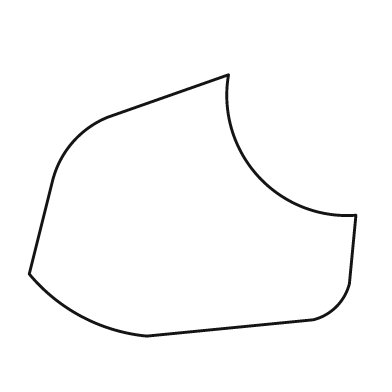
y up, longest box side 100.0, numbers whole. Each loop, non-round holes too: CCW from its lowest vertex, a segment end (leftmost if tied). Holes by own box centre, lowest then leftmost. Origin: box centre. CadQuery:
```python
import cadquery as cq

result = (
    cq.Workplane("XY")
    .moveTo(-14.0, -40.0)
    .lineTo(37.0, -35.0)
    .threePointArc((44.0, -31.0), (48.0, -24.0))
    .lineTo(50.0, -3.0)
    .threePointArc((20.0, 9.0), (11.0, 40.0))
    .lineTo(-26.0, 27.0)
    .threePointArc((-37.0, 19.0), (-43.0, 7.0))
    .lineTo(-50.0, -21.0)
    .threePointArc((-34.0, -34.0), (-14.0, -40.0))
    .close()
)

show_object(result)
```